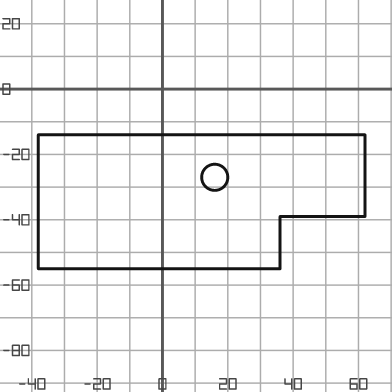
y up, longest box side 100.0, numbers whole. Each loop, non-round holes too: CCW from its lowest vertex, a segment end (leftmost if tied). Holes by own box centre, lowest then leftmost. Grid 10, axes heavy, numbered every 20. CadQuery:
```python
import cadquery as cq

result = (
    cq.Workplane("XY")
    .moveTo(-38.0, -55.0)
    .lineTo(36.0, -55.0)
    .lineTo(36.0, -39.0)
    .lineTo(62.0, -39.0)
    .lineTo(62.0, -14.0)
    .lineTo(-38.0, -14.0)
    .close()
    .moveTo(16.0, -27.0)
    .circle(4.0)
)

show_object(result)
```